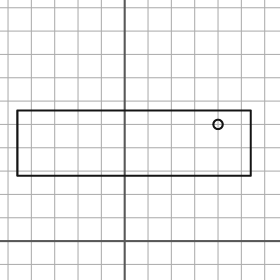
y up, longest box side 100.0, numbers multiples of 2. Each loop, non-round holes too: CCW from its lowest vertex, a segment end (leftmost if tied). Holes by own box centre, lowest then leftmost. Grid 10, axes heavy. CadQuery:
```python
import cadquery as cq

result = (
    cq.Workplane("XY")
    .moveTo(-46.0, 28.0)
    .lineTo(54.0, 28.0)
    .lineTo(54.0, 56.0)
    .lineTo(-46.0, 56.0)
    .close()
    .moveTo(40.0, 50.0)
    .circle(2.0)
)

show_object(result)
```